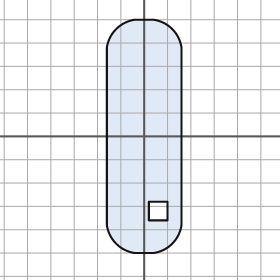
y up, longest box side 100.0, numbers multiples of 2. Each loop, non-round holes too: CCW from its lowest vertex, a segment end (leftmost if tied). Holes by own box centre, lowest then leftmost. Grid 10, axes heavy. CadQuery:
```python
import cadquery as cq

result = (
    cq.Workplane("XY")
    .moveTo(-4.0, -50.0)
    .lineTo(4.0, -50.0)
    .threePointArc((12.0, -46.0), (16.0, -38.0))
    .lineTo(16.0, 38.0)
    .threePointArc((12.0, 46.0), (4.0, 50.0))
    .lineTo(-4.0, 50.0)
    .threePointArc((-12.0, 46.0), (-16.0, 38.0))
    .lineTo(-16.0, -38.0)
    .threePointArc((-12.0, -46.0), (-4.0, -50.0))
    .close()
    .moveTo(2.0, -36.0)
    .lineTo(10.0, -36.0)
    .lineTo(10.0, -28.0)
    .lineTo(2.0, -28.0)
    .close()
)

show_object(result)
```